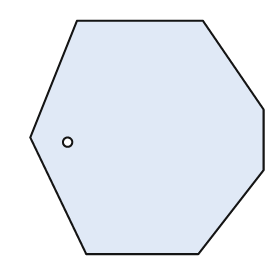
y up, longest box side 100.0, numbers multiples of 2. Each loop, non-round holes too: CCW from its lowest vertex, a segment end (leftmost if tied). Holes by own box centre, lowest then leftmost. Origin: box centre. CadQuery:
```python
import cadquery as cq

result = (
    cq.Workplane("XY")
    .moveTo(-26.0, -50.0)
    .lineTo(22.0, -50.0)
    .lineTo(50.0, -14.0)
    .lineTo(50.0, 12.0)
    .lineTo(24.0, 50.0)
    .lineTo(-30.0, 50.0)
    .lineTo(-50.0, 0.0)
    .close()
    .moveTo(-34.0, -2.0)
    .circle(2.0)
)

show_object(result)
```